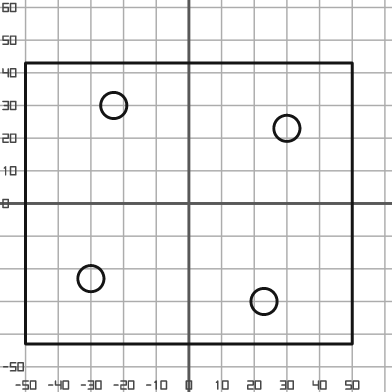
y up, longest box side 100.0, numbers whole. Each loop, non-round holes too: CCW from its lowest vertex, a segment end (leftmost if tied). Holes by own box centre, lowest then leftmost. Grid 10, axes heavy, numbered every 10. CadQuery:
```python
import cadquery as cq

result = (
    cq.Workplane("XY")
    .moveTo(-50.0, -43.0)
    .lineTo(50.0, -43.0)
    .lineTo(50.0, 43.0)
    .lineTo(-50.0, 43.0)
    .close()
    .moveTo(23.0, -30.0)
    .circle(4.0)
    .moveTo(-30.0, -23.0)
    .circle(4.0)
    .moveTo(30.0, 23.0)
    .circle(4.0)
    .moveTo(-23.0, 30.0)
    .circle(4.0)
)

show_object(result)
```